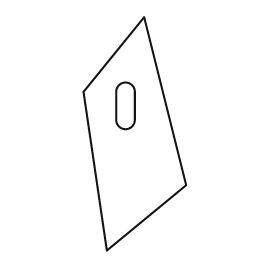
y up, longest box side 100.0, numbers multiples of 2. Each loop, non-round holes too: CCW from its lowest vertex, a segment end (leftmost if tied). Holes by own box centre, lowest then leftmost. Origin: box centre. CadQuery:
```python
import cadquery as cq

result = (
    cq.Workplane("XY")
    .moveTo(-12.0, -50.0)
    .lineTo(22.0, -22.0)
    .lineTo(4.0, 50.0)
    .lineTo(-22.0, 18.0)
    .close()
    .moveTo(-8.0, 6.0)
    .threePointArc((-4.0, 2.0), (0.0, 6.0))
    .lineTo(0.0, 18.0)
    .threePointArc((-4.0, 22.0), (-8.0, 18.0))
    .close()
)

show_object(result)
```